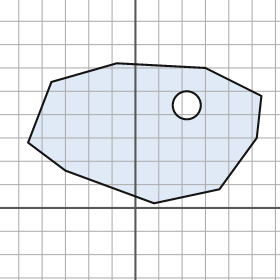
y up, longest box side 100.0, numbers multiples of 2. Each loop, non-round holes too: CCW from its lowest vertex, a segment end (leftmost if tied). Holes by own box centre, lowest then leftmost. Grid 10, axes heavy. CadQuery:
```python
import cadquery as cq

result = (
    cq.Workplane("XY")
    .moveTo(8.0, 2.0)
    .lineTo(36.0, 8.0)
    .lineTo(52.0, 30.0)
    .lineTo(54.0, 48.0)
    .lineTo(30.0, 60.0)
    .lineTo(-8.0, 62.0)
    .lineTo(-36.0, 54.0)
    .lineTo(-46.0, 28.0)
    .lineTo(-30.0, 16.0)
    .close()
    .moveTo(22.0, 44.0)
    .circle(6.0)
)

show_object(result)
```